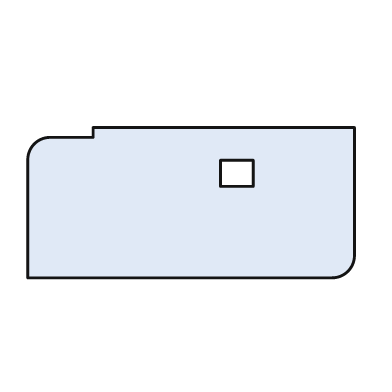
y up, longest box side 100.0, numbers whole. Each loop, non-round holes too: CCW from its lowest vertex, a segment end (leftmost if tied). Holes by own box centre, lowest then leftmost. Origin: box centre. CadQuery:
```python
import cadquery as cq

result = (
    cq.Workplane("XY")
    .moveTo(-50.0, -23.0)
    .lineTo(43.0, -23.0)
    .threePointArc((48.0, -21.0), (50.0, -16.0))
    .lineTo(50.0, 23.0)
    .lineTo(-30.0, 23.0)
    .lineTo(-30.0, 20.0)
    .lineTo(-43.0, 20.0)
    .threePointArc((-48.0, 18.0), (-50.0, 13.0))
    .close()
    .moveTo(9.0, 5.0)
    .lineTo(19.0, 5.0)
    .lineTo(19.0, 13.0)
    .lineTo(9.0, 13.0)
    .close()
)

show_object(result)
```